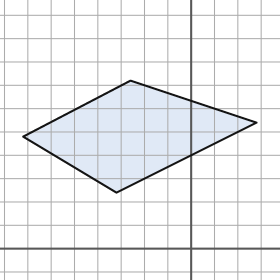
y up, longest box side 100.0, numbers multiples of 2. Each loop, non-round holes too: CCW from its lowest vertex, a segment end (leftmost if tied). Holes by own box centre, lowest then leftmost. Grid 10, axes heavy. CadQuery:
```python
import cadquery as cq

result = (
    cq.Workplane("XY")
    .moveTo(-32.0, 24.0)
    .lineTo(28.0, 54.0)
    .lineTo(-26.0, 72.0)
    .lineTo(-72.0, 48.0)
    .close()
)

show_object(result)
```